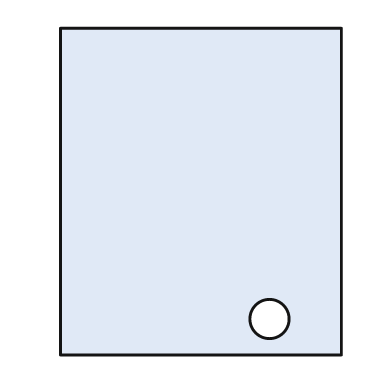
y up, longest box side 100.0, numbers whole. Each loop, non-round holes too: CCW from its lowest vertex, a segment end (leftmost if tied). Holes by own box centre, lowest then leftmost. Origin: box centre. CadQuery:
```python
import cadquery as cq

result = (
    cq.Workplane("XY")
    .moveTo(-43.0, -50.0)
    .lineTo(43.0, -50.0)
    .lineTo(43.0, 50.0)
    .lineTo(-43.0, 50.0)
    .close()
    .moveTo(21.0, -39.0)
    .circle(6.0)
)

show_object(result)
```